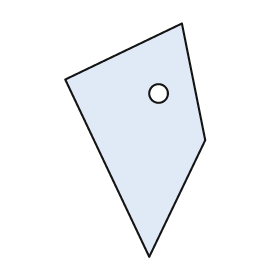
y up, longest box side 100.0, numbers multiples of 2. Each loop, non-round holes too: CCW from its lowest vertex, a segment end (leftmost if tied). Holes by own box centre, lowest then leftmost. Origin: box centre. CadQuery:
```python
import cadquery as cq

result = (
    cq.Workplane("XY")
    .moveTo(6.0, -50.0)
    .lineTo(30.0, 0.0)
    .lineTo(20.0, 50.0)
    .lineTo(-30.0, 26.0)
    .close()
    .moveTo(10.0, 20.0)
    .circle(4.0)
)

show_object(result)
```